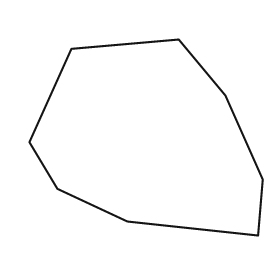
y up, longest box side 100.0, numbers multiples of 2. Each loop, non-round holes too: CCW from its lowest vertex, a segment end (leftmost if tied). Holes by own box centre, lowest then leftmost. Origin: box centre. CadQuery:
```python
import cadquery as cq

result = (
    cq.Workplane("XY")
    .moveTo(48.0, -42.0)
    .lineTo(50.0, -18.0)
    .lineTo(34.0, 18.0)
    .lineTo(14.0, 42.0)
    .lineTo(-32.0, 38.0)
    .lineTo(-50.0, -2.0)
    .lineTo(-38.0, -22.0)
    .lineTo(-8.0, -36.0)
    .close()
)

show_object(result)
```